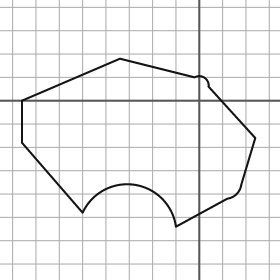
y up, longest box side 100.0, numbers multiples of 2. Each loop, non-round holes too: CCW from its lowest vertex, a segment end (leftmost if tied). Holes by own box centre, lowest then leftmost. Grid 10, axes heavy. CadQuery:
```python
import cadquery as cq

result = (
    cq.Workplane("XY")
    .moveTo(-10.0, -54.0)
    .lineTo(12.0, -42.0)
    .threePointArc((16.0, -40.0), (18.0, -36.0))
    .lineTo(24.0, -16.0)
    .lineTo(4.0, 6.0)
    .threePointArc((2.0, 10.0), (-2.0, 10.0))
    .lineTo(-34.0, 18.0)
    .lineTo(-76.0, 0.0)
    .lineTo(-76.0, -18.0)
    .lineTo(-50.0, -48.0)
    .threePointArc((-28.0, -36.0), (-10.0, -54.0))
    .close()
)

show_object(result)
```